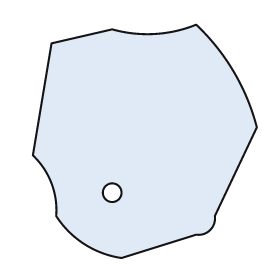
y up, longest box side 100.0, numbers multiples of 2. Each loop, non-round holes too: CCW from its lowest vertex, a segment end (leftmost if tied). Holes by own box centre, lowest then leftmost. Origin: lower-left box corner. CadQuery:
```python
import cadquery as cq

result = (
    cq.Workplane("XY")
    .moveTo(38.0, 0.0)
    .lineTo(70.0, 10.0)
    .threePointArc((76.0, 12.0), (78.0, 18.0))
    .lineTo(96.0, 56.0)
    .threePointArc((86.0, 80.0), (70.0, 100.0))
    .threePointArc((52.0, 96.0), (34.0, 98.0))
    .lineTo(8.0, 92.0)
    .lineTo(0.0, 44.0)
    .threePointArc((8.0, 32.0), (10.0, 18.0))
    .threePointArc((22.0, 6.0), (38.0, 0.0))
    .close()
    .moveTo(34.0, 28.0)
    .circle(4.0)
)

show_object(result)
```